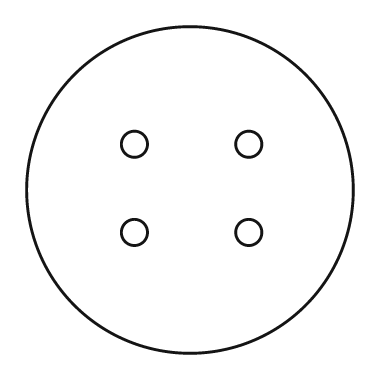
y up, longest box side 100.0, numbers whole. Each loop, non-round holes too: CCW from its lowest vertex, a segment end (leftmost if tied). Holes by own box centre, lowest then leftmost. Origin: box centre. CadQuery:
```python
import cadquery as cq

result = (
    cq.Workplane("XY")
    .moveTo(0.0, 0.0)
    .circle(50.0)
    .moveTo(-17.0, -13.0)
    .circle(4.0)
    .moveTo(18.0, -13.0)
    .circle(4.0)
    .moveTo(-17.0, 14.0)
    .circle(4.0)
    .moveTo(18.0, 14.0)
    .circle(4.0)
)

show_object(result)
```